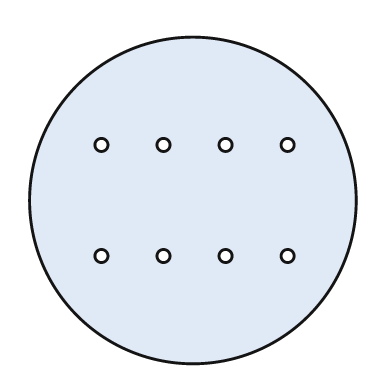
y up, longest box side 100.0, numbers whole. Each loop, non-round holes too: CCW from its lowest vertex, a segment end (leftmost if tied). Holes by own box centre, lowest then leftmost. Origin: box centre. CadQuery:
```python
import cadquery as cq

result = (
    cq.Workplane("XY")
    .moveTo(0.0, 0.0)
    .circle(50.0)
    .moveTo(-28.0, -17.0)
    .circle(2.0)
    .moveTo(-9.0, -17.0)
    .circle(2.0)
    .moveTo(10.0, -17.0)
    .circle(2.0)
    .moveTo(29.0, -17.0)
    .circle(2.0)
    .moveTo(-28.0, 17.0)
    .circle(2.0)
    .moveTo(-9.0, 17.0)
    .circle(2.0)
    .moveTo(10.0, 17.0)
    .circle(2.0)
    .moveTo(29.0, 17.0)
    .circle(2.0)
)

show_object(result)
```